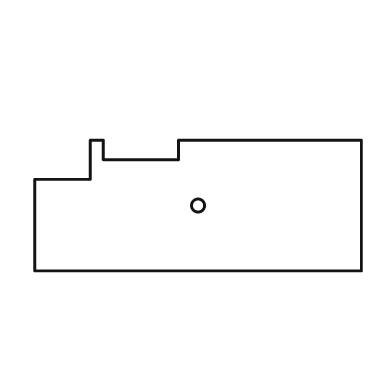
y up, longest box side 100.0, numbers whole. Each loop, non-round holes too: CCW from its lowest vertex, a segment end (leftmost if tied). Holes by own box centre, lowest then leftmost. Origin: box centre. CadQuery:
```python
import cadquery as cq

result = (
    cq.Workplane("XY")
    .moveTo(-50.0, -20.0)
    .lineTo(50.0, -20.0)
    .lineTo(50.0, 20.0)
    .lineTo(-6.0, 20.0)
    .lineTo(-6.0, 14.0)
    .lineTo(-29.0, 14.0)
    .lineTo(-29.0, 20.0)
    .lineTo(-33.0, 20.0)
    .lineTo(-33.0, 8.0)
    .lineTo(-50.0, 8.0)
    .close()
    .moveTo(0.0, 0.0)
    .circle(2.0)
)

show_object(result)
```